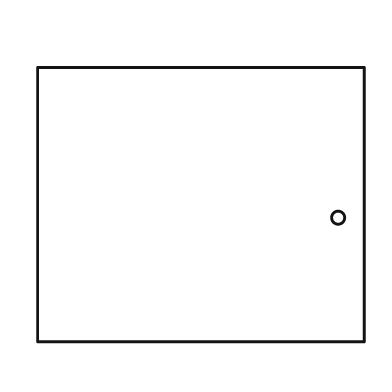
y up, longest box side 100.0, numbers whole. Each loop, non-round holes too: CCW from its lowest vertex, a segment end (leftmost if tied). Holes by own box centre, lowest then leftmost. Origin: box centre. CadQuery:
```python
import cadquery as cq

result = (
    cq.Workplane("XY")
    .moveTo(-50.0, -42.0)
    .lineTo(50.0, -42.0)
    .lineTo(50.0, 42.0)
    .lineTo(-50.0, 42.0)
    .close()
    .moveTo(42.0, -4.0)
    .circle(2.0)
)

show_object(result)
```